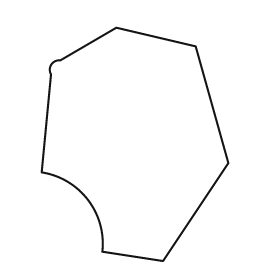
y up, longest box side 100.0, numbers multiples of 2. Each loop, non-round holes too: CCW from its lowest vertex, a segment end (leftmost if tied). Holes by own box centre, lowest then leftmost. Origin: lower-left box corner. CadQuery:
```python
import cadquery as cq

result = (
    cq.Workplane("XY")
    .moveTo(52.0, 0.0)
    .lineTo(80.0, 42.0)
    .lineTo(66.0, 92.0)
    .lineTo(32.0, 100.0)
    .lineTo(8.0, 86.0)
    .threePointArc((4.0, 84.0), (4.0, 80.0))
    .lineTo(0.0, 38.0)
    .threePointArc((20.0, 26.0), (26.0, 4.0))
    .close()
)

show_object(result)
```